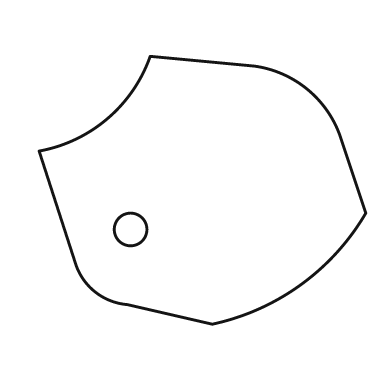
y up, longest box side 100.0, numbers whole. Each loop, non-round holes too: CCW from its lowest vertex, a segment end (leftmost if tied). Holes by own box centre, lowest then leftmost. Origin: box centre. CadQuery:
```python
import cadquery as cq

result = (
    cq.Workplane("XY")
    .moveTo(3.0, -41.0)
    .threePointArc((30.0, -29.0), (50.0, -7.0))
    .lineTo(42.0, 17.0)
    .threePointArc((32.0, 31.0), (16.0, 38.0))
    .lineTo(-16.0, 41.0)
    .threePointArc((-29.0, 22.0), (-50.0, 12.0))
    .lineTo(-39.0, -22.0)
    .threePointArc((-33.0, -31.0), (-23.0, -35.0))
    .close()
    .moveTo(-22.0, -12.0)
    .circle(5.0)
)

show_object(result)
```